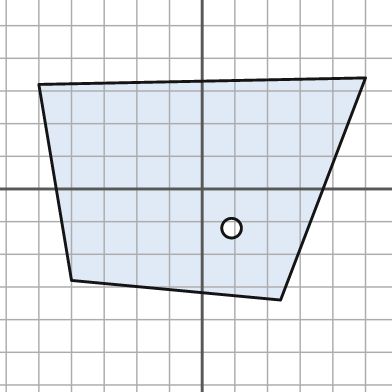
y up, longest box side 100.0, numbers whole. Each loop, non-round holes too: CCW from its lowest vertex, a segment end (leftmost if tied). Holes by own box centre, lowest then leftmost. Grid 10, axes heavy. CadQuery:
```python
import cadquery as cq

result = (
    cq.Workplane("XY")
    .moveTo(24.0, -34.0)
    .lineTo(50.0, 34.0)
    .lineTo(-50.0, 32.0)
    .lineTo(-40.0, -28.0)
    .close()
    .moveTo(9.0, -12.0)
    .circle(3.0)
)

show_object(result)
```